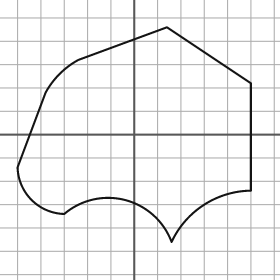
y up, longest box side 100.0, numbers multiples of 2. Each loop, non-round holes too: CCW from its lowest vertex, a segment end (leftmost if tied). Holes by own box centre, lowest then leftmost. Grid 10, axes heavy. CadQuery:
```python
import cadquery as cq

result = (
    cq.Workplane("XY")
    .moveTo(16.0, -46.0)
    .threePointArc((30.0, -30.0), (50.0, -24.0))
    .lineTo(50.0, 22.0)
    .lineTo(14.0, 46.0)
    .lineTo(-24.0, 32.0)
    .threePointArc((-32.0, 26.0), (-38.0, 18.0))
    .lineTo(-50.0, -14.0)
    .threePointArc((-44.0, -28.0), (-30.0, -34.0))
    .threePointArc((-4.0, -28.0), (16.0, -46.0))
    .close()
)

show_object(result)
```